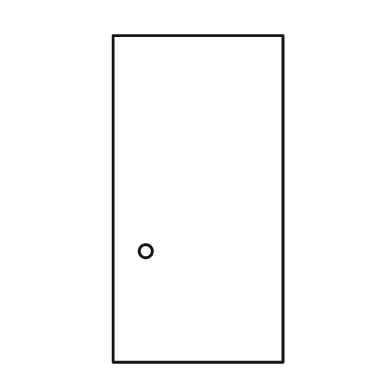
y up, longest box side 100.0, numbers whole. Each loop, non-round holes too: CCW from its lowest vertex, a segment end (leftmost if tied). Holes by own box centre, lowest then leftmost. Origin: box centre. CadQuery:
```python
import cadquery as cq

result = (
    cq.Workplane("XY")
    .moveTo(-26.0, -50.0)
    .lineTo(26.0, -50.0)
    .lineTo(26.0, 50.0)
    .lineTo(-26.0, 50.0)
    .close()
    .moveTo(-16.0, -16.0)
    .circle(2.0)
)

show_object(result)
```